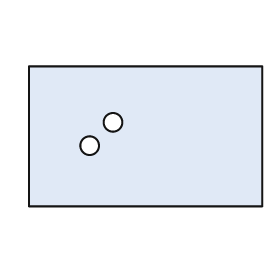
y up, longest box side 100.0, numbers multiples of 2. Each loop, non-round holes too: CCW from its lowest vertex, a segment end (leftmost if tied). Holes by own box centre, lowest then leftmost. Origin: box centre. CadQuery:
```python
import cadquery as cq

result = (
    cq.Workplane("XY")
    .moveTo(-50.0, -30.0)
    .lineTo(50.0, -30.0)
    .lineTo(50.0, 30.0)
    .lineTo(-50.0, 30.0)
    .close()
    .moveTo(-24.0, -4.0)
    .circle(4.0)
    .moveTo(-14.0, 6.0)
    .circle(4.0)
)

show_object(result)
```